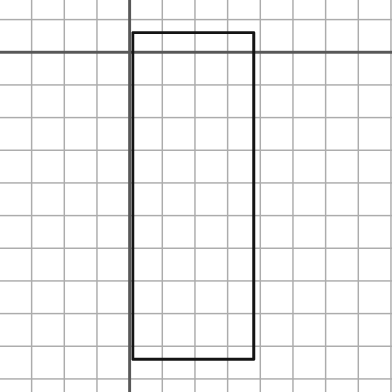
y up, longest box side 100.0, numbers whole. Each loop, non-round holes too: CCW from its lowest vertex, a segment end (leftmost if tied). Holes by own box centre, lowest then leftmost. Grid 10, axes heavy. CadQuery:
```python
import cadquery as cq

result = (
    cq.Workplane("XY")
    .moveTo(1.0, -94.0)
    .lineTo(38.0, -94.0)
    .lineTo(38.0, 6.0)
    .lineTo(1.0, 6.0)
    .close()
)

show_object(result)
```